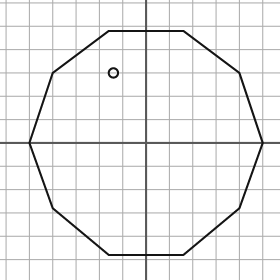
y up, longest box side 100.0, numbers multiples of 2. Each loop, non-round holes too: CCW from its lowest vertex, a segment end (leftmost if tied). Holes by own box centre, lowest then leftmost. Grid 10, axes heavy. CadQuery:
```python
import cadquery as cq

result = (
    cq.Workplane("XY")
    .moveTo(-16.0, -48.0)
    .lineTo(16.0, -48.0)
    .lineTo(40.0, -28.0)
    .lineTo(50.0, 0.0)
    .lineTo(40.0, 30.0)
    .lineTo(16.0, 48.0)
    .lineTo(-16.0, 48.0)
    .lineTo(-40.0, 30.0)
    .lineTo(-50.0, 0.0)
    .lineTo(-40.0, -28.0)
    .close()
    .moveTo(-14.0, 30.0)
    .circle(2.0)
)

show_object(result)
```